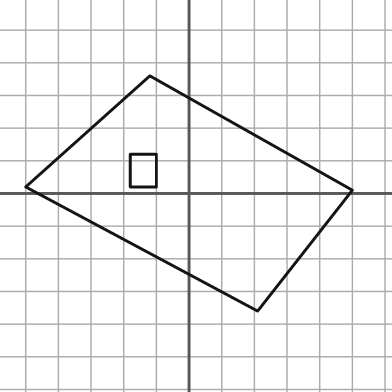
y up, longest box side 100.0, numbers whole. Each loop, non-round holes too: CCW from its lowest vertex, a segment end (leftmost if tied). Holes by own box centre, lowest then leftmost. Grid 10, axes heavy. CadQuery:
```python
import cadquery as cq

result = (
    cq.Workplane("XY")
    .moveTo(21.0, -36.0)
    .lineTo(50.0, 1.0)
    .lineTo(-12.0, 36.0)
    .lineTo(-50.0, 2.0)
    .close()
    .moveTo(-18.0, 2.0)
    .lineTo(-10.0, 2.0)
    .lineTo(-10.0, 12.0)
    .lineTo(-18.0, 12.0)
    .close()
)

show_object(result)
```